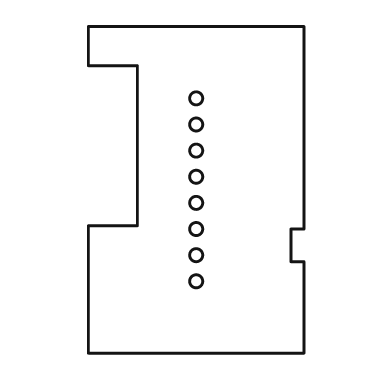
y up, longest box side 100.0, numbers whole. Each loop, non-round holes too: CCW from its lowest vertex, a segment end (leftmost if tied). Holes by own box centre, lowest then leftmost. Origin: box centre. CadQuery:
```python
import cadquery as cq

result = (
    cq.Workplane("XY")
    .moveTo(-33.0, -50.0)
    .lineTo(33.0, -50.0)
    .lineTo(33.0, -22.0)
    .lineTo(29.0, -22.0)
    .lineTo(29.0, -12.0)
    .lineTo(33.0, -12.0)
    .lineTo(33.0, 50.0)
    .lineTo(-33.0, 50.0)
    .lineTo(-33.0, 38.0)
    .lineTo(-18.0, 38.0)
    .lineTo(-18.0, -11.0)
    .lineTo(-33.0, -11.0)
    .close()
    .moveTo(0.0, -28.0)
    .circle(2.0)
    .moveTo(0.0, -20.0)
    .circle(2.0)
    .moveTo(0.0, -12.0)
    .circle(2.0)
    .moveTo(0.0, -4.0)
    .circle(2.0)
    .moveTo(0.0, 4.0)
    .circle(2.0)
    .moveTo(0.0, 12.0)
    .circle(2.0)
    .moveTo(0.0, 20.0)
    .circle(2.0)
    .moveTo(0.0, 28.0)
    .circle(2.0)
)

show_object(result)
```